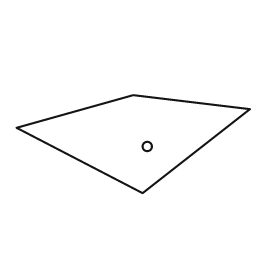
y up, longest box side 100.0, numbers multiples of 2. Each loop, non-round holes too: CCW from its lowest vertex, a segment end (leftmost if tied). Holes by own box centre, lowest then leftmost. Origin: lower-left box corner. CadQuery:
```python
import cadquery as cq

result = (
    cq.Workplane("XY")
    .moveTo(54.0, 0.0)
    .lineTo(100.0, 36.0)
    .lineTo(50.0, 42.0)
    .lineTo(0.0, 28.0)
    .close()
    .moveTo(56.0, 20.0)
    .circle(2.0)
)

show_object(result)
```